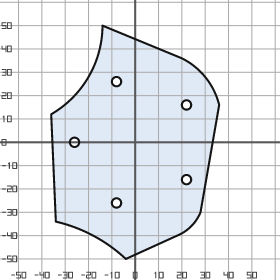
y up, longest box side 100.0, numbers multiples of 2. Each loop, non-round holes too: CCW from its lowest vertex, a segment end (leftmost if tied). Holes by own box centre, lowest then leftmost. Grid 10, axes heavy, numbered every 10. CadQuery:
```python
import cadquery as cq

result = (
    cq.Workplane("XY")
    .moveTo(-4.0, -50.0)
    .lineTo(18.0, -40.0)
    .threePointArc((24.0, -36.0), (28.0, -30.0))
    .lineTo(36.0, 16.0)
    .threePointArc((30.0, 28.0), (20.0, 36.0))
    .lineTo(-14.0, 50.0)
    .threePointArc((-20.0, 28.0), (-36.0, 12.0))
    .lineTo(-34.0, -34.0)
    .threePointArc((-18.0, -40.0), (-4.0, -50.0))
    .close()
    .moveTo(-8.0, -26.0)
    .circle(2.0)
    .moveTo(22.0, -16.0)
    .circle(2.0)
    .moveTo(-26.0, 0.0)
    .circle(2.0)
    .moveTo(22.0, 16.0)
    .circle(2.0)
    .moveTo(-8.0, 26.0)
    .circle(2.0)
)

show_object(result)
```